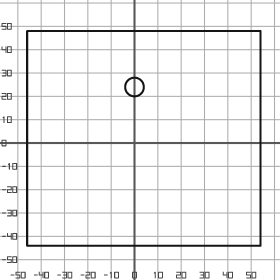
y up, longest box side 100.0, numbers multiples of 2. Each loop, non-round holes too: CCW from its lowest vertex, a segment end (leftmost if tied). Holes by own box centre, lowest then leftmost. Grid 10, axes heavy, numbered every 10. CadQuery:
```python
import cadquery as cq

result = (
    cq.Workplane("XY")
    .moveTo(-46.0, -44.0)
    .lineTo(54.0, -44.0)
    .lineTo(54.0, 48.0)
    .lineTo(-46.0, 48.0)
    .close()
    .moveTo(0.0, 24.0)
    .circle(4.0)
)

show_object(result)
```